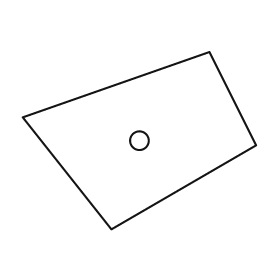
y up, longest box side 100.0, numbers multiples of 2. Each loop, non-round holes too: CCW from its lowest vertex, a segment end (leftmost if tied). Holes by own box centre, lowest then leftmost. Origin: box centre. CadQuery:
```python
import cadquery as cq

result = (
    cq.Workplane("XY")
    .moveTo(-12.0, -38.0)
    .lineTo(50.0, -2.0)
    .lineTo(30.0, 38.0)
    .lineTo(-50.0, 10.0)
    .close()
    .moveTo(0.0, 0.0)
    .circle(4.0)
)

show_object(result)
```